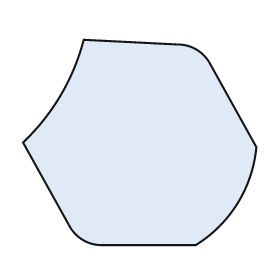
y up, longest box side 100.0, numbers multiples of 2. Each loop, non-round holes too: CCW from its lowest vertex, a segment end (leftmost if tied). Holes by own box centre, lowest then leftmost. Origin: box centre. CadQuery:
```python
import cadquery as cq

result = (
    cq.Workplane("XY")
    .moveTo(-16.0, -44.0)
    .lineTo(24.0, -44.0)
    .threePointArc((42.0, -26.0), (50.0, -2.0))
    .lineTo(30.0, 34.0)
    .threePointArc((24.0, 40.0), (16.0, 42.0))
    .lineTo(-24.0, 44.0)
    .threePointArc((-34.0, 20.0), (-50.0, 0.0))
    .lineTo(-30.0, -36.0)
    .threePointArc((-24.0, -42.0), (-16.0, -44.0))
    .close()
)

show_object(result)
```